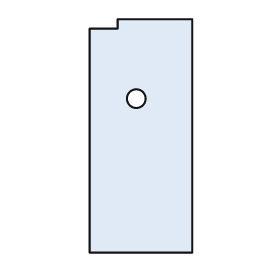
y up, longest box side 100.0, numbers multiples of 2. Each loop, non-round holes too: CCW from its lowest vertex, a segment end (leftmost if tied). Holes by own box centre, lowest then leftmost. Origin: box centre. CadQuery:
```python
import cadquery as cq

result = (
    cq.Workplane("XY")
    .moveTo(-22.0, -50.0)
    .lineTo(22.0, -50.0)
    .lineTo(22.0, 50.0)
    .lineTo(-10.0, 50.0)
    .lineTo(-10.0, 46.0)
    .lineTo(-22.0, 46.0)
    .close()
    .moveTo(-2.0, 16.0)
    .circle(4.0)
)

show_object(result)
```